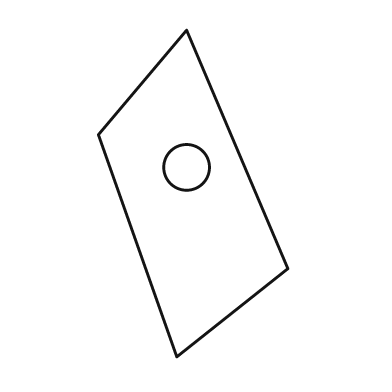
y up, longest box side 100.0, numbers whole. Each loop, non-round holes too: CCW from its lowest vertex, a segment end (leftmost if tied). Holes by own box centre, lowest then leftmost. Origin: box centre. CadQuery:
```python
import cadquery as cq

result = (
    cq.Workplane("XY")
    .moveTo(-5.0, -50.0)
    .lineTo(29.0, -23.0)
    .lineTo(-2.0, 50.0)
    .lineTo(-29.0, 18.0)
    .close()
    .moveTo(-2.0, 8.0)
    .circle(7.0)
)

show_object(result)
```